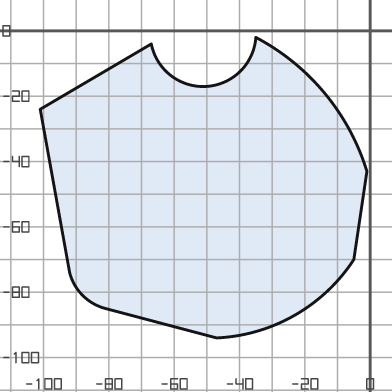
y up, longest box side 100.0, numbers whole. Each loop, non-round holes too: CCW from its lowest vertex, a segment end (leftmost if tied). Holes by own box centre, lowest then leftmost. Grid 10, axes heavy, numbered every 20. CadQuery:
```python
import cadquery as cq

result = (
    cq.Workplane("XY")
    .moveTo(-47.0, -94.0)
    .threePointArc((-23.0, -87.0), (-5.0, -70.0))
    .lineTo(-1.0, -43.0)
    .threePointArc((-14.0, -19.0), (-35.0, -2.0))
    .threePointArc((-50.0, -17.0), (-67.0, -4.0))
    .lineTo(-101.0, -24.0)
    .lineTo(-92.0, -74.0)
    .threePointArc((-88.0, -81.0), (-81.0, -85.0))
    .close()
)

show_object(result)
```